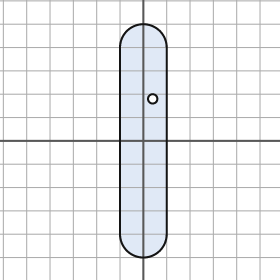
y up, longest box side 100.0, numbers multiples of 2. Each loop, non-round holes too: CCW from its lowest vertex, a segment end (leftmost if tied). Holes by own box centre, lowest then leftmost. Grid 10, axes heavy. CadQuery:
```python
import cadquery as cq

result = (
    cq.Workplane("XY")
    .moveTo(-10.0, -40.0)
    .threePointArc((0.0, -50.0), (10.0, -40.0))
    .lineTo(10.0, 40.0)
    .threePointArc((0.0, 50.0), (-10.0, 40.0))
    .close()
    .moveTo(4.0, 18.0)
    .circle(2.0)
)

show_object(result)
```